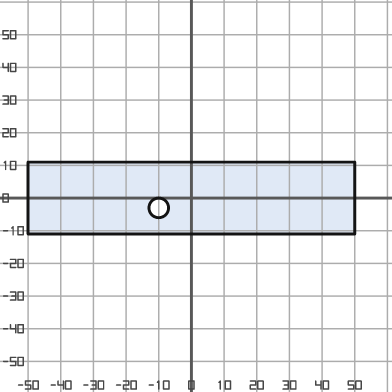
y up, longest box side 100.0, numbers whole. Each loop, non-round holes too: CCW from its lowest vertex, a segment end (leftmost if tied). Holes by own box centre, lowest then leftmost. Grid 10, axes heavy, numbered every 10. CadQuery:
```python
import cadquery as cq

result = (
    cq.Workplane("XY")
    .moveTo(-50.0, -11.0)
    .lineTo(50.0, -11.0)
    .lineTo(50.0, 11.0)
    .lineTo(-50.0, 11.0)
    .close()
    .moveTo(-10.0, -3.0)
    .circle(3.0)
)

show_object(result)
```